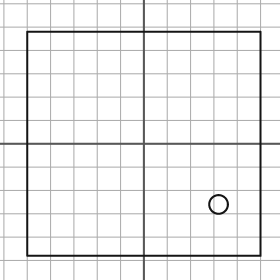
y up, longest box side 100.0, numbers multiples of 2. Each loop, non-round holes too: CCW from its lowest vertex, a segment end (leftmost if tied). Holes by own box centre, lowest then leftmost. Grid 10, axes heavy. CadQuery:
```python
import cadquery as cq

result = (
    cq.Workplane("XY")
    .moveTo(-50.0, -48.0)
    .lineTo(50.0, -48.0)
    .lineTo(50.0, 48.0)
    .lineTo(-50.0, 48.0)
    .close()
    .moveTo(32.0, -26.0)
    .circle(4.0)
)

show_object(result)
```